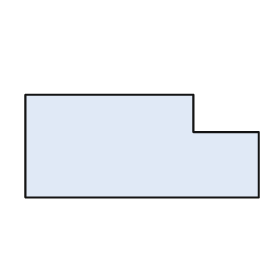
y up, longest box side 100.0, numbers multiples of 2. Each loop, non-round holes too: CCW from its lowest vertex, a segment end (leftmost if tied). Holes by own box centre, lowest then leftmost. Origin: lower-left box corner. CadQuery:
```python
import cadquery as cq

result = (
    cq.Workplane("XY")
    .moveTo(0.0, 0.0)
    .lineTo(100.0, 0.0)
    .lineTo(100.0, 28.0)
    .lineTo(72.0, 28.0)
    .lineTo(72.0, 44.0)
    .lineTo(0.0, 44.0)
    .close()
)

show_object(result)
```